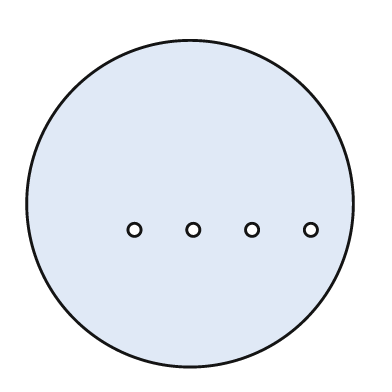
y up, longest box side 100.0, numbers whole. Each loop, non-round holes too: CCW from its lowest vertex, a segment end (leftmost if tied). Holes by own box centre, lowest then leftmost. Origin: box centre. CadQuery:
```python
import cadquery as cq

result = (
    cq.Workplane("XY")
    .moveTo(0.0, 0.0)
    .circle(50.0)
    .moveTo(-17.0, -8.0)
    .circle(2.0)
    .moveTo(1.0, -8.0)
    .circle(2.0)
    .moveTo(19.0, -8.0)
    .circle(2.0)
    .moveTo(37.0, -8.0)
    .circle(2.0)
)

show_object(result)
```